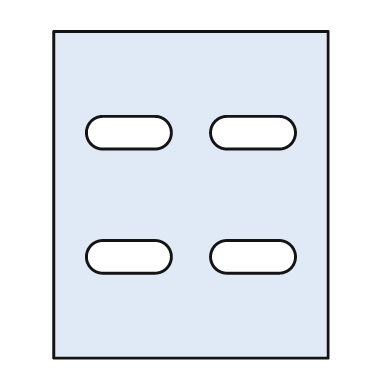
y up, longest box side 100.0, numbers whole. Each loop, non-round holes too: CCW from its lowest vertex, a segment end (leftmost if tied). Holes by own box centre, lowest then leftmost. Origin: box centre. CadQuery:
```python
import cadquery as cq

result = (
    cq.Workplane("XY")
    .moveTo(-42.0, -50.0)
    .lineTo(42.0, -50.0)
    .lineTo(42.0, 50.0)
    .lineTo(-42.0, 50.0)
    .close()
    .moveTo(-27.0, -24.0)
    .lineTo(-11.0, -24.0)
    .threePointArc((-6.0, -19.0), (-11.0, -14.0))
    .lineTo(-27.0, -14.0)
    .threePointArc((-32.0, -19.0), (-27.0, -24.0))
    .close()
    .moveTo(11.0, -24.0)
    .lineTo(27.0, -24.0)
    .threePointArc((32.0, -19.0), (27.0, -14.0))
    .lineTo(11.0, -14.0)
    .threePointArc((6.0, -19.0), (11.0, -24.0))
    .close()
    .moveTo(-27.0, 14.0)
    .lineTo(-11.0, 14.0)
    .threePointArc((-6.0, 19.0), (-11.0, 24.0))
    .lineTo(-27.0, 24.0)
    .threePointArc((-32.0, 19.0), (-27.0, 14.0))
    .close()
    .moveTo(11.0, 14.0)
    .lineTo(27.0, 14.0)
    .threePointArc((32.0, 19.0), (27.0, 24.0))
    .lineTo(11.0, 24.0)
    .threePointArc((6.0, 19.0), (11.0, 14.0))
    .close()
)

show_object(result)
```